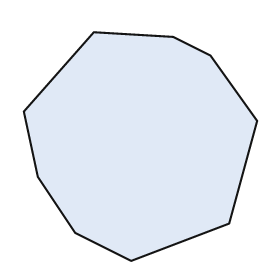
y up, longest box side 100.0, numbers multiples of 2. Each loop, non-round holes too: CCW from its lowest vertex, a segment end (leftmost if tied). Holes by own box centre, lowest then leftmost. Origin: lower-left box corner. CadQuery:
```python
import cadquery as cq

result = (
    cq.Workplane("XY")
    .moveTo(46.0, 0.0)
    .lineTo(88.0, 16.0)
    .lineTo(100.0, 60.0)
    .lineTo(80.0, 88.0)
    .lineTo(64.0, 96.0)
    .lineTo(30.0, 98.0)
    .lineTo(0.0, 64.0)
    .lineTo(6.0, 36.0)
    .lineTo(22.0, 12.0)
    .close()
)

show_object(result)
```